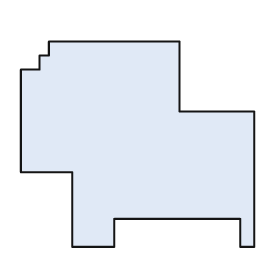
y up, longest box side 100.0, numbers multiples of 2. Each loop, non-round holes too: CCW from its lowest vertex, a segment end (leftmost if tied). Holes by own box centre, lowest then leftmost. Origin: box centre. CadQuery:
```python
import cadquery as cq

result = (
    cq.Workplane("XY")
    .moveTo(-28.0, -44.0)
    .lineTo(-10.0, -44.0)
    .lineTo(-10.0, -32.0)
    .lineTo(44.0, -32.0)
    .lineTo(44.0, -44.0)
    .lineTo(50.0, -44.0)
    .lineTo(50.0, 14.0)
    .lineTo(18.0, 14.0)
    .lineTo(18.0, 44.0)
    .lineTo(-38.0, 44.0)
    .lineTo(-38.0, 38.0)
    .lineTo(-42.0, 38.0)
    .lineTo(-42.0, 32.0)
    .lineTo(-50.0, 32.0)
    .lineTo(-50.0, -12.0)
    .lineTo(-28.0, -12.0)
    .close()
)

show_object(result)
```